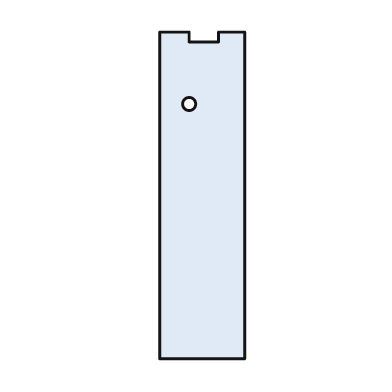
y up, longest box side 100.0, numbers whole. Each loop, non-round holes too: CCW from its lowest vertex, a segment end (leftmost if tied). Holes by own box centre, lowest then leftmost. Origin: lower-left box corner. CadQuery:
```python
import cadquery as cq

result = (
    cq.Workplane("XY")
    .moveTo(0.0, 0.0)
    .lineTo(26.0, 0.0)
    .lineTo(26.0, 100.0)
    .lineTo(18.0, 100.0)
    .lineTo(18.0, 97.0)
    .lineTo(9.0, 97.0)
    .lineTo(9.0, 100.0)
    .lineTo(0.0, 100.0)
    .close()
    .moveTo(9.0, 78.0)
    .circle(2.0)
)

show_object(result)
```